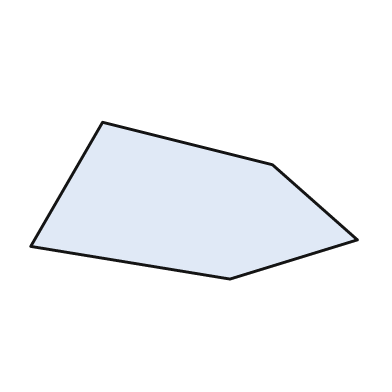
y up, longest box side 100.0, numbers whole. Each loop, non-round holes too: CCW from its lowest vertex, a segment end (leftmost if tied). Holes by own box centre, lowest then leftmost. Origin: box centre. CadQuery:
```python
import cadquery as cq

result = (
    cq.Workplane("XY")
    .moveTo(11.0, -24.0)
    .lineTo(50.0, -12.0)
    .lineTo(24.0, 11.0)
    .lineTo(-28.0, 24.0)
    .lineTo(-50.0, -14.0)
    .close()
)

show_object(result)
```